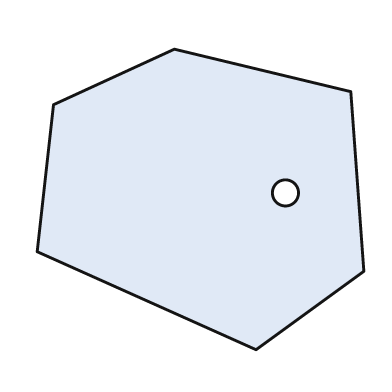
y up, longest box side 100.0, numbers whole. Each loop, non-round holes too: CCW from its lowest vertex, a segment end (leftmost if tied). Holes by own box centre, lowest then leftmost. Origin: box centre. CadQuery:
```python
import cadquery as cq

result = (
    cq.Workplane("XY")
    .moveTo(17.0, -46.0)
    .lineTo(50.0, -22.0)
    .lineTo(46.0, 33.0)
    .lineTo(-8.0, 46.0)
    .lineTo(-45.0, 29.0)
    .lineTo(-50.0, -16.0)
    .close()
    .moveTo(26.0, 2.0)
    .circle(4.0)
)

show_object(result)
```